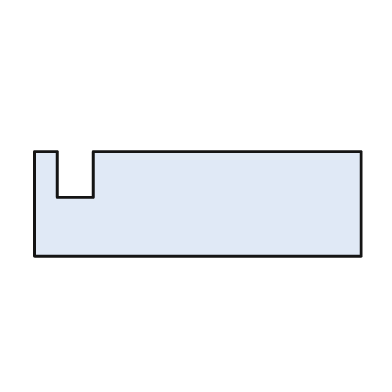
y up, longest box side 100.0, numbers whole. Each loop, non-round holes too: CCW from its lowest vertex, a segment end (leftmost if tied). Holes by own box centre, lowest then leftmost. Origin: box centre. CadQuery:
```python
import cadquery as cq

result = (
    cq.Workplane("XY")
    .moveTo(-50.0, -16.0)
    .lineTo(50.0, -16.0)
    .lineTo(50.0, 16.0)
    .lineTo(-32.0, 16.0)
    .lineTo(-32.0, 2.0)
    .lineTo(-43.0, 2.0)
    .lineTo(-43.0, 16.0)
    .lineTo(-50.0, 16.0)
    .close()
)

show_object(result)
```